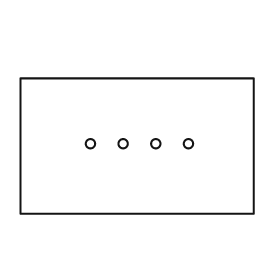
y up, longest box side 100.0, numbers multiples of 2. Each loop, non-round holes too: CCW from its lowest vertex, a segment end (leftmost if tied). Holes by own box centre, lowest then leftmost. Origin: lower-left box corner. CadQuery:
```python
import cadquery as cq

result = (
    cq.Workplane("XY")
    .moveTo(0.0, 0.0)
    .lineTo(100.0, 0.0)
    .lineTo(100.0, 58.0)
    .lineTo(0.0, 58.0)
    .close()
    .moveTo(30.0, 30.0)
    .circle(2.0)
    .moveTo(44.0, 30.0)
    .circle(2.0)
    .moveTo(58.0, 30.0)
    .circle(2.0)
    .moveTo(72.0, 30.0)
    .circle(2.0)
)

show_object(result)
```